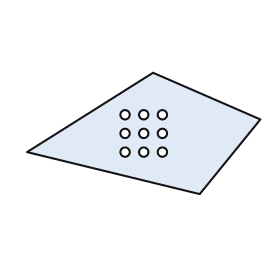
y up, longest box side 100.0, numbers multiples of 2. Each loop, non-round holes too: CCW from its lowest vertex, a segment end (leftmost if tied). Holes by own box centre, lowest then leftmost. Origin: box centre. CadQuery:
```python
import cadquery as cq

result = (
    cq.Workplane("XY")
    .moveTo(24.0, -26.0)
    .lineTo(50.0, 6.0)
    .lineTo(4.0, 26.0)
    .lineTo(-50.0, -8.0)
    .close()
    .moveTo(-8.0, -8.0)
    .circle(2.0)
    .moveTo(0.0, -8.0)
    .circle(2.0)
    .moveTo(8.0, -8.0)
    .circle(2.0)
    .moveTo(-8.0, 0.0)
    .circle(2.0)
    .moveTo(0.0, 0.0)
    .circle(2.0)
    .moveTo(8.0, 0.0)
    .circle(2.0)
    .moveTo(-8.0, 8.0)
    .circle(2.0)
    .moveTo(0.0, 8.0)
    .circle(2.0)
    .moveTo(8.0, 8.0)
    .circle(2.0)
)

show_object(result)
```